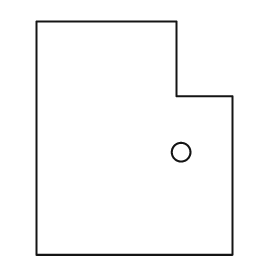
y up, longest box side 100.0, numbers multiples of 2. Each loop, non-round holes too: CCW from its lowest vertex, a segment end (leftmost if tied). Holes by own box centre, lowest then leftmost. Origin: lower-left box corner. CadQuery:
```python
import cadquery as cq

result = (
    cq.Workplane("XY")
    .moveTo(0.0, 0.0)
    .lineTo(84.0, 0.0)
    .lineTo(84.0, 68.0)
    .lineTo(60.0, 68.0)
    .lineTo(60.0, 100.0)
    .lineTo(0.0, 100.0)
    .close()
    .moveTo(62.0, 44.0)
    .circle(4.0)
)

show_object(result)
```